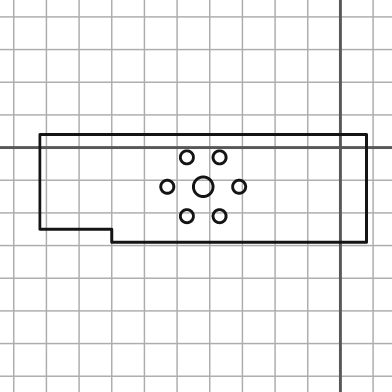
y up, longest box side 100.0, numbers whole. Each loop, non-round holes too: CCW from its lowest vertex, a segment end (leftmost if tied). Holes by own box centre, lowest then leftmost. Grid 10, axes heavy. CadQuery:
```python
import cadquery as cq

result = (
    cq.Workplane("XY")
    .moveTo(-70.0, -29.0)
    .lineTo(8.0, -29.0)
    .lineTo(8.0, 4.0)
    .lineTo(-92.0, 4.0)
    .lineTo(-92.0, -25.0)
    .lineTo(-70.0, -25.0)
    .close()
    .moveTo(-47.0, -21.0)
    .circle(2.0)
    .moveTo(-37.0, -21.0)
    .circle(2.0)
    .moveTo(-53.0, -12.0)
    .circle(2.0)
    .moveTo(-42.0, -12.0)
    .circle(3.0)
    .moveTo(-31.0, -12.0)
    .circle(2.0)
    .moveTo(-47.0, -3.0)
    .circle(2.0)
    .moveTo(-37.0, -3.0)
    .circle(2.0)
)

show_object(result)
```